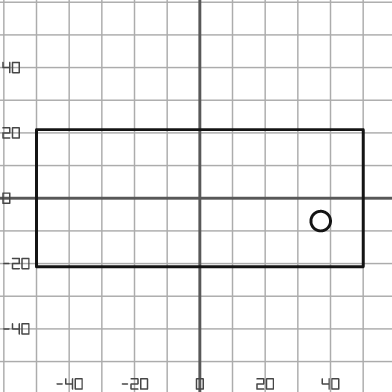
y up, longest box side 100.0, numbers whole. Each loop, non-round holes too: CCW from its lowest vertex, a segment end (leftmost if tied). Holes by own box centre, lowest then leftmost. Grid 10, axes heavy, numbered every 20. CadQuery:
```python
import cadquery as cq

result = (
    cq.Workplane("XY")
    .moveTo(-50.0, -21.0)
    .lineTo(50.0, -21.0)
    .lineTo(50.0, 21.0)
    .lineTo(-50.0, 21.0)
    .close()
    .moveTo(37.0, -7.0)
    .circle(3.0)
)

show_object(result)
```